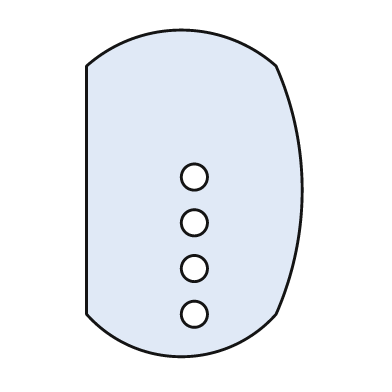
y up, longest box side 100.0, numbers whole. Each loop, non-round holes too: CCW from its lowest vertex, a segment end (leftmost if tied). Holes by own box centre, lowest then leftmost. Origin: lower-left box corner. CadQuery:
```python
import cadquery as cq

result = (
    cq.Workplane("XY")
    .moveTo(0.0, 13.0)
    .threePointArc((29.0, 0.0), (58.0, 13.0))
    .threePointArc((66.0, 51.0), (58.0, 89.0))
    .threePointArc((29.0, 100.0), (0.0, 89.0))
    .close()
    .moveTo(33.0, 13.0)
    .circle(4.0)
    .moveTo(33.0, 27.0)
    .circle(4.0)
    .moveTo(33.0, 41.0)
    .circle(4.0)
    .moveTo(33.0, 55.0)
    .circle(4.0)
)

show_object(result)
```